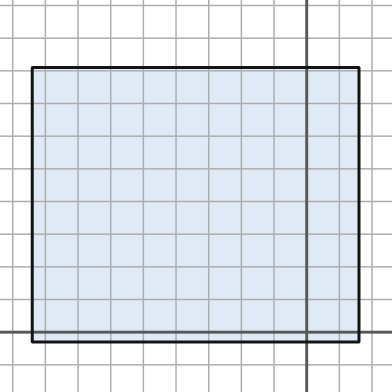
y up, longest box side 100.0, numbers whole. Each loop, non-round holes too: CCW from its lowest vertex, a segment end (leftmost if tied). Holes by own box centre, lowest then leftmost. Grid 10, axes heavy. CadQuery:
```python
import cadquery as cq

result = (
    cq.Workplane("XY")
    .moveTo(-84.0, -3.0)
    .lineTo(16.0, -3.0)
    .lineTo(16.0, 81.0)
    .lineTo(-84.0, 81.0)
    .close()
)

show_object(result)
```